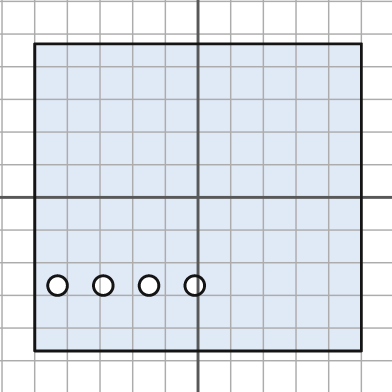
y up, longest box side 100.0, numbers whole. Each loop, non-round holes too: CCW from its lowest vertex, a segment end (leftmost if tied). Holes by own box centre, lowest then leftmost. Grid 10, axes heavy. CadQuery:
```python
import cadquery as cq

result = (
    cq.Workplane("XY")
    .moveTo(-50.0, -47.0)
    .lineTo(50.0, -47.0)
    .lineTo(50.0, 47.0)
    .lineTo(-50.0, 47.0)
    .close()
    .moveTo(-43.0, -27.0)
    .circle(3.0)
    .moveTo(-29.0, -27.0)
    .circle(3.0)
    .moveTo(-15.0, -27.0)
    .circle(3.0)
    .moveTo(-1.0, -27.0)
    .circle(3.0)
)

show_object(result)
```